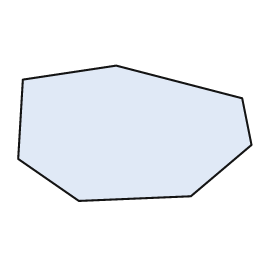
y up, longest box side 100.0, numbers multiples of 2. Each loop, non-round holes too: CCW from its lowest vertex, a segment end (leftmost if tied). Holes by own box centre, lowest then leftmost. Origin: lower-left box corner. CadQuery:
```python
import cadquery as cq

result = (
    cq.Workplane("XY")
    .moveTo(26.0, 0.0)
    .lineTo(74.0, 2.0)
    .lineTo(100.0, 24.0)
    .lineTo(96.0, 44.0)
    .lineTo(42.0, 58.0)
    .lineTo(2.0, 52.0)
    .lineTo(0.0, 18.0)
    .close()
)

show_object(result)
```